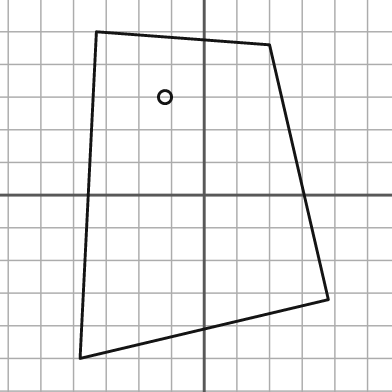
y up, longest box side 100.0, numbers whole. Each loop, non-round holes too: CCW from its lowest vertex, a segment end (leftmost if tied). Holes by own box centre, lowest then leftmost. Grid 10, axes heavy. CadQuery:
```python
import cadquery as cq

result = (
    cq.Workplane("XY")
    .moveTo(-38.0, -50.0)
    .lineTo(38.0, -32.0)
    .lineTo(20.0, 46.0)
    .lineTo(-33.0, 50.0)
    .close()
    .moveTo(-12.0, 30.0)
    .circle(2.0)
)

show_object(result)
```